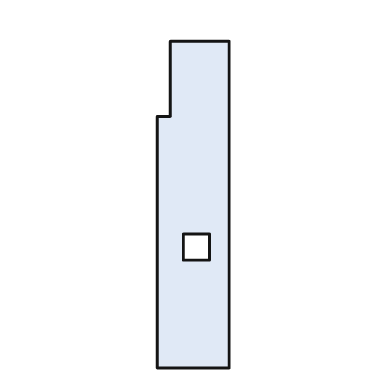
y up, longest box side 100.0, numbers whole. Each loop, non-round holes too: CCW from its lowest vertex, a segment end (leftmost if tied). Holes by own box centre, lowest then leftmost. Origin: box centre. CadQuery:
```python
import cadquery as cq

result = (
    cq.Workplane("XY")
    .moveTo(-11.0, -50.0)
    .lineTo(11.0, -50.0)
    .lineTo(11.0, 50.0)
    .lineTo(-7.0, 50.0)
    .lineTo(-7.0, 27.0)
    .lineTo(-11.0, 27.0)
    .close()
    .moveTo(-3.0, -17.0)
    .lineTo(5.0, -17.0)
    .lineTo(5.0, -9.0)
    .lineTo(-3.0, -9.0)
    .close()
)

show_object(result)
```